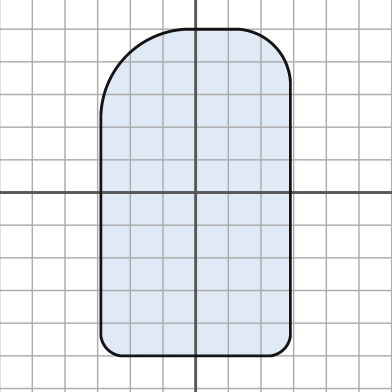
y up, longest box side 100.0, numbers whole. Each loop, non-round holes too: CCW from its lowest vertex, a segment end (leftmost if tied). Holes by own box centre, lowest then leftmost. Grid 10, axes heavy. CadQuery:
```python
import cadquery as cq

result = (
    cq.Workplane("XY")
    .moveTo(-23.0, -50.0)
    .lineTo(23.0, -50.0)
    .threePointArc((27.0, -48.0), (29.0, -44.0))
    .lineTo(29.0, 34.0)
    .threePointArc((24.0, 45.0), (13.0, 50.0))
    .lineTo(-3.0, 50.0)
    .threePointArc((-21.0, 42.0), (-29.0, 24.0))
    .lineTo(-29.0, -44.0)
    .threePointArc((-27.0, -48.0), (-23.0, -50.0))
    .close()
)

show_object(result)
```